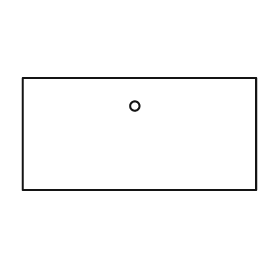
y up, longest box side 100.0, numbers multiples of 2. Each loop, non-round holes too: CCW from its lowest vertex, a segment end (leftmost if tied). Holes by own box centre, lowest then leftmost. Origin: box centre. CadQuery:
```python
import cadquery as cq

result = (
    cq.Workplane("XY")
    .moveTo(-50.0, -24.0)
    .lineTo(50.0, -24.0)
    .lineTo(50.0, 24.0)
    .lineTo(-50.0, 24.0)
    .close()
    .moveTo(-2.0, 12.0)
    .circle(2.0)
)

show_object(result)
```